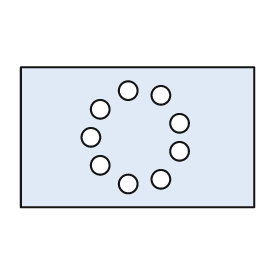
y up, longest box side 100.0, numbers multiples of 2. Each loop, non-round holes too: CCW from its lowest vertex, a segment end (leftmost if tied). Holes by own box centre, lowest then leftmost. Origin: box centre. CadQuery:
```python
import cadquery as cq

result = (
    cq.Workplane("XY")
    .moveTo(-50.0, -30.0)
    .lineTo(50.0, -30.0)
    .lineTo(50.0, 30.0)
    .lineTo(-50.0, 30.0)
    .close()
    .moveTo(-4.0, -20.0)
    .circle(4.0)
    .moveTo(10.0, -18.0)
    .circle(4.0)
    .moveTo(-16.0, -12.0)
    .circle(4.0)
    .moveTo(18.0, -6.0)
    .circle(4.0)
    .moveTo(-20.0, 0.0)
    .circle(4.0)
    .moveTo(18.0, 6.0)
    .circle(4.0)
    .moveTo(-16.0, 12.0)
    .circle(4.0)
    .moveTo(10.0, 18.0)
    .circle(4.0)
    .moveTo(-4.0, 20.0)
    .circle(4.0)
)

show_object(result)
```